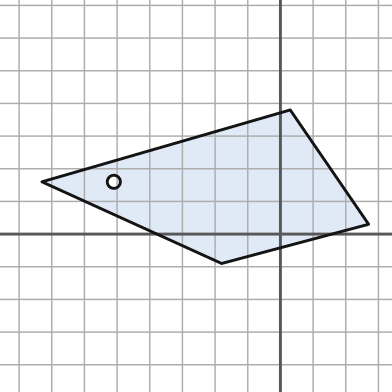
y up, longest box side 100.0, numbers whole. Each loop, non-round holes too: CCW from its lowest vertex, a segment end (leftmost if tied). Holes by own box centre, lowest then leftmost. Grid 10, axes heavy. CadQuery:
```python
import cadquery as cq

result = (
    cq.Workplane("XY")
    .moveTo(-18.0, -9.0)
    .lineTo(27.0, 3.0)
    .lineTo(3.0, 38.0)
    .lineTo(-73.0, 16.0)
    .close()
    .moveTo(-51.0, 16.0)
    .circle(2.0)
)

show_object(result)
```